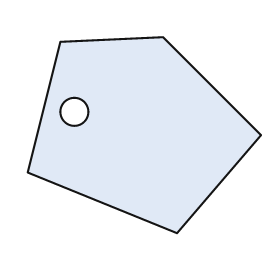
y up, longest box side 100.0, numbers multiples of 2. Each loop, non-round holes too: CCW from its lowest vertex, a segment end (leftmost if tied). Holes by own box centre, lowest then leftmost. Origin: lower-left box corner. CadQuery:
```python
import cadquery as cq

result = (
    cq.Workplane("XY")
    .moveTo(64.0, 0.0)
    .lineTo(100.0, 42.0)
    .lineTo(58.0, 84.0)
    .lineTo(14.0, 82.0)
    .lineTo(0.0, 26.0)
    .close()
    .moveTo(20.0, 52.0)
    .circle(6.0)
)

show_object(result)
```